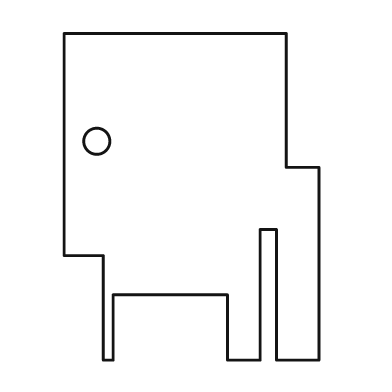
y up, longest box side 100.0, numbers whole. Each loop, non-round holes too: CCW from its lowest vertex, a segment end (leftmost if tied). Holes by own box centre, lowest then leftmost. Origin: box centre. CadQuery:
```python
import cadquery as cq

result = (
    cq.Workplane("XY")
    .moveTo(-27.0, -50.0)
    .lineTo(-24.0, -50.0)
    .lineTo(-24.0, -30.0)
    .lineTo(11.0, -30.0)
    .lineTo(11.0, -50.0)
    .lineTo(21.0, -50.0)
    .lineTo(21.0, -10.0)
    .lineTo(26.0, -10.0)
    .lineTo(26.0, -50.0)
    .lineTo(39.0, -50.0)
    .lineTo(39.0, 9.0)
    .lineTo(29.0, 9.0)
    .lineTo(29.0, 50.0)
    .lineTo(-39.0, 50.0)
    .lineTo(-39.0, -18.0)
    .lineTo(-27.0, -18.0)
    .close()
    .moveTo(-29.0, 17.0)
    .circle(4.0)
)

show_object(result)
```